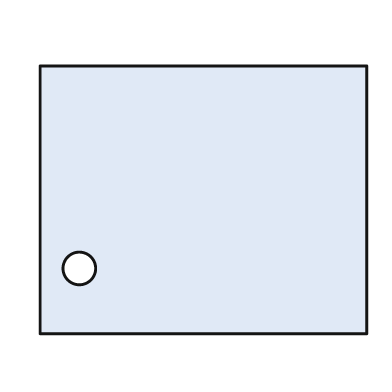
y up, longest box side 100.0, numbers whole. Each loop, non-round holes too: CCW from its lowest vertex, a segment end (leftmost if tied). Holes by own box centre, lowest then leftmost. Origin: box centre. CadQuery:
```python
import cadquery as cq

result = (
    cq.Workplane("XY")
    .moveTo(-50.0, -41.0)
    .lineTo(50.0, -41.0)
    .lineTo(50.0, 41.0)
    .lineTo(-50.0, 41.0)
    .close()
    .moveTo(-38.0, -21.0)
    .circle(5.0)
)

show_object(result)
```